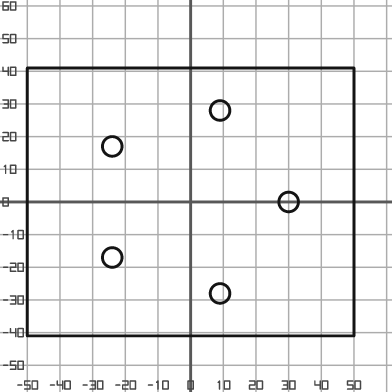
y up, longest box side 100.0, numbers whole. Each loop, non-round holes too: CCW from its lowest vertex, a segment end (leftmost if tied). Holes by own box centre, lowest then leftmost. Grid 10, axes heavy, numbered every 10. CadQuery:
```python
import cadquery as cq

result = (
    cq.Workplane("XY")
    .moveTo(-50.0, -41.0)
    .lineTo(50.0, -41.0)
    .lineTo(50.0, 41.0)
    .lineTo(-50.0, 41.0)
    .close()
    .moveTo(9.0, -28.0)
    .circle(3.0)
    .moveTo(-24.0, -17.0)
    .circle(3.0)
    .moveTo(30.0, 0.0)
    .circle(3.0)
    .moveTo(-24.0, 17.0)
    .circle(3.0)
    .moveTo(9.0, 28.0)
    .circle(3.0)
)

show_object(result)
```